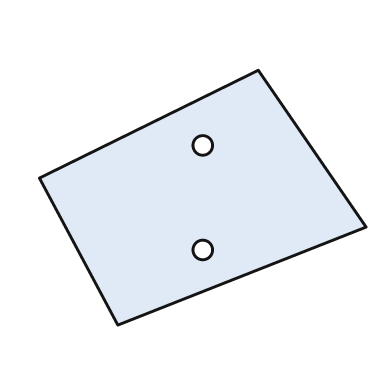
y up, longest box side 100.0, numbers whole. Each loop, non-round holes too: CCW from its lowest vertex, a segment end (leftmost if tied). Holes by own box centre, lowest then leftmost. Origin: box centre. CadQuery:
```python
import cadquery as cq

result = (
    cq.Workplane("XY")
    .moveTo(-26.0, -39.0)
    .lineTo(50.0, -9.0)
    .lineTo(17.0, 39.0)
    .lineTo(-50.0, 6.0)
    .close()
    .moveTo(0.0, -16.0)
    .circle(3.0)
    .moveTo(0.0, 16.0)
    .circle(3.0)
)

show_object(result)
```